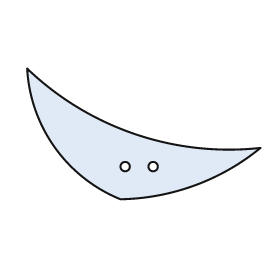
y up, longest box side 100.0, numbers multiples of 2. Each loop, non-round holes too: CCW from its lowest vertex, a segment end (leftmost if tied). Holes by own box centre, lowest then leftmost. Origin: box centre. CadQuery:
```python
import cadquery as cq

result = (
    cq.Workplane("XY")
    .moveTo(-10.0, -28.0)
    .threePointArc((22.0, -22.0), (50.0, -6.0))
    .threePointArc((-4.0, 0.0), (-50.0, 28.0))
    .threePointArc((-38.0, -6.0), (-10.0, -28.0))
    .close()
    .moveTo(-8.0, -14.0)
    .circle(2.0)
    .moveTo(4.0, -14.0)
    .circle(2.0)
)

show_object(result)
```